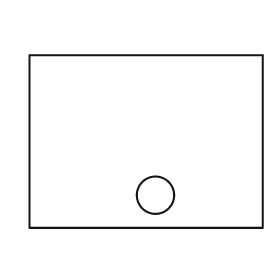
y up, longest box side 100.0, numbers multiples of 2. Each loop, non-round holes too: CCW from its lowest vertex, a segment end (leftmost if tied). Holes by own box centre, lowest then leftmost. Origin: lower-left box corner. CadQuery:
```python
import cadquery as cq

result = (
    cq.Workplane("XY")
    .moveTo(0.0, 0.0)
    .lineTo(100.0, 0.0)
    .lineTo(100.0, 74.0)
    .lineTo(0.0, 74.0)
    .close()
    .moveTo(54.0, 14.0)
    .circle(8.0)
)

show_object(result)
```